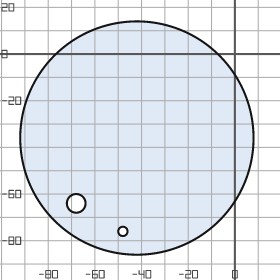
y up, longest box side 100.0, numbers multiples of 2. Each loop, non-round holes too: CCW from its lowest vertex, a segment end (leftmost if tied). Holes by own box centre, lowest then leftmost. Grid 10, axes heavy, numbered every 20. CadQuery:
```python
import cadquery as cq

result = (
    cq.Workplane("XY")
    .moveTo(-42.0, -36.0)
    .circle(50.0)
    .moveTo(-48.0, -76.0)
    .circle(2.0)
    .moveTo(-68.0, -64.0)
    .circle(4.0)
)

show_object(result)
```